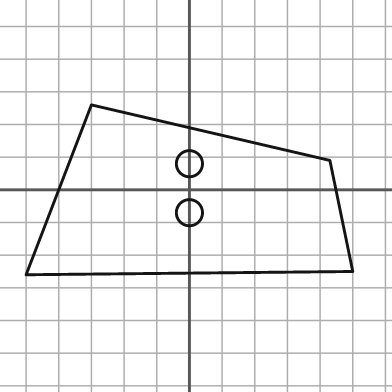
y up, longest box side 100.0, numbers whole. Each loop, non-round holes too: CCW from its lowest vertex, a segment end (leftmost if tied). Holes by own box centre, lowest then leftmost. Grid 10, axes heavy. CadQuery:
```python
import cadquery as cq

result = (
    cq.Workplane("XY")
    .moveTo(-50.0, -26.0)
    .lineTo(50.0, -25.0)
    .lineTo(43.0, 9.0)
    .lineTo(-30.0, 26.0)
    .close()
    .moveTo(0.0, -7.0)
    .circle(4.0)
    .moveTo(0.0, 8.0)
    .circle(4.0)
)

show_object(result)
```